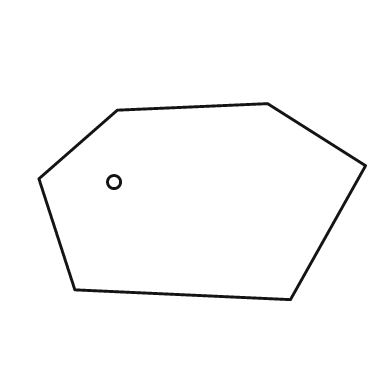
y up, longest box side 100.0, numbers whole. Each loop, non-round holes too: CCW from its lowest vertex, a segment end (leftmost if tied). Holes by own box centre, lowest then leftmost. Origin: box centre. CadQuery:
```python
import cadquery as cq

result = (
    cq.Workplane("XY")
    .moveTo(27.0, -30.0)
    .lineTo(50.0, 11.0)
    .lineTo(20.0, 30.0)
    .lineTo(-26.0, 28.0)
    .lineTo(-50.0, 7.0)
    .lineTo(-39.0, -27.0)
    .close()
    .moveTo(-27.0, 6.0)
    .circle(2.0)
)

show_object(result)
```